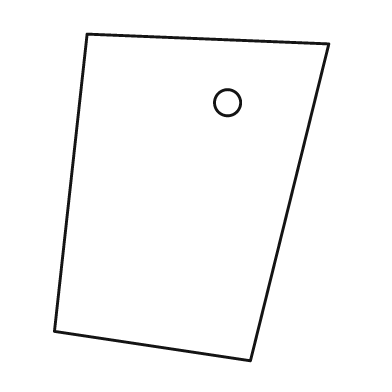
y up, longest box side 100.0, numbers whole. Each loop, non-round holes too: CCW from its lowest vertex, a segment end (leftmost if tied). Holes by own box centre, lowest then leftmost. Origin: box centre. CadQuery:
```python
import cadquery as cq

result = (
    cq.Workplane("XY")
    .moveTo(18.0, -50.0)
    .lineTo(42.0, 47.0)
    .lineTo(-32.0, 50.0)
    .lineTo(-42.0, -41.0)
    .close()
    .moveTo(11.0, 29.0)
    .circle(4.0)
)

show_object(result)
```